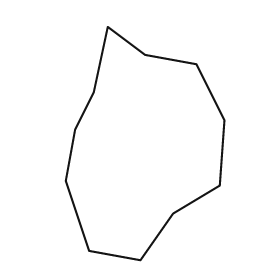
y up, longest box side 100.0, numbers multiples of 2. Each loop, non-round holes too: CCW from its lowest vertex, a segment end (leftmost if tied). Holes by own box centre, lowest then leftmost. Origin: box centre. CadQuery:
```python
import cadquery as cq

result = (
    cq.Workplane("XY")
    .moveTo(-2.0, -50.0)
    .lineTo(12.0, -30.0)
    .lineTo(32.0, -18.0)
    .lineTo(34.0, 10.0)
    .lineTo(22.0, 34.0)
    .lineTo(0.0, 38.0)
    .lineTo(-16.0, 50.0)
    .lineTo(-22.0, 22.0)
    .lineTo(-30.0, 6.0)
    .lineTo(-34.0, -16.0)
    .lineTo(-24.0, -46.0)
    .close()
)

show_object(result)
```